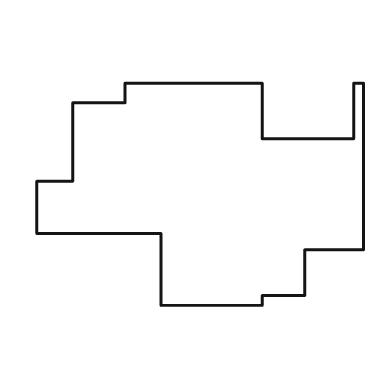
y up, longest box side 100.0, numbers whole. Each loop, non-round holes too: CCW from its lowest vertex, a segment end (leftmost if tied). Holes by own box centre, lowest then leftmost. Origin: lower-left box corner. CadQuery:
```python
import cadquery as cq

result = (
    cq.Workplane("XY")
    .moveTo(38.0, 0.0)
    .lineTo(69.0, 0.0)
    .lineTo(69.0, 3.0)
    .lineTo(82.0, 3.0)
    .lineTo(82.0, 17.0)
    .lineTo(100.0, 17.0)
    .lineTo(100.0, 68.0)
    .lineTo(97.0, 68.0)
    .lineTo(97.0, 51.0)
    .lineTo(69.0, 51.0)
    .lineTo(69.0, 68.0)
    .lineTo(27.0, 68.0)
    .lineTo(27.0, 62.0)
    .lineTo(11.0, 62.0)
    .lineTo(11.0, 38.0)
    .lineTo(0.0, 38.0)
    .lineTo(0.0, 22.0)
    .lineTo(38.0, 22.0)
    .close()
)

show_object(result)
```